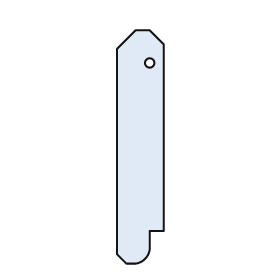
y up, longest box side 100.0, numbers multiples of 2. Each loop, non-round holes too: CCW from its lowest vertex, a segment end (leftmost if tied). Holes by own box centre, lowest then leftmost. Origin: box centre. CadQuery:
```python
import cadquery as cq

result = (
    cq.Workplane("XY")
    .moveTo(-6.0, -50.0)
    .lineTo(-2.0, -50.0)
    .threePointArc((2.0, -48.0), (4.0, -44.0))
    .lineTo(4.0, -36.0)
    .lineTo(10.0, -36.0)
    .lineTo(10.0, 44.0)
    .lineTo(4.0, 50.0)
    .lineTo(-2.0, 50.0)
    .lineTo(-10.0, 42.0)
    .lineTo(-10.0, -46.0)
    .close()
    .moveTo(4.0, 36.0)
    .circle(2.0)
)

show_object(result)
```